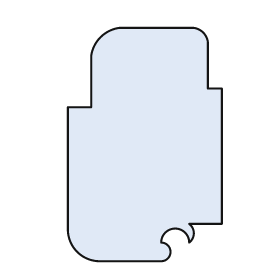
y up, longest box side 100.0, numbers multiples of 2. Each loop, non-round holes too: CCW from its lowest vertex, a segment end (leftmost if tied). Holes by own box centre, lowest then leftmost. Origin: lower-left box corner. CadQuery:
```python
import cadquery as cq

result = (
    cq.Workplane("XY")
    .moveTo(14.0, 0.0)
    .lineTo(40.0, 0.0)
    .threePointArc((44.0, 4.0), (40.0, 8.0))
    .threePointArc((46.0, 14.0), (52.0, 8.0))
    .threePointArc((54.0, 12.0), (52.0, 16.0))
    .lineTo(66.0, 16.0)
    .lineTo(66.0, 74.0)
    .lineTo(60.0, 74.0)
    .lineTo(60.0, 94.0)
    .threePointArc((58.0, 98.0), (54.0, 100.0))
    .lineTo(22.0, 100.0)
    .threePointArc((14.0, 96.0), (10.0, 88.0))
    .lineTo(10.0, 66.0)
    .lineTo(0.0, 66.0)
    .lineTo(0.0, 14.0)
    .threePointArc((4.0, 4.0), (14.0, 0.0))
    .close()
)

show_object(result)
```